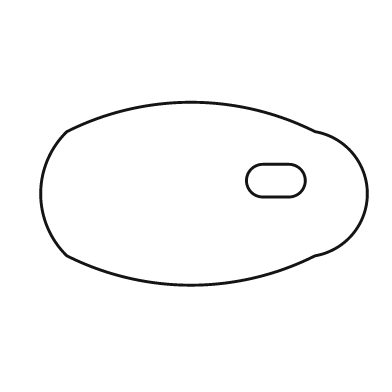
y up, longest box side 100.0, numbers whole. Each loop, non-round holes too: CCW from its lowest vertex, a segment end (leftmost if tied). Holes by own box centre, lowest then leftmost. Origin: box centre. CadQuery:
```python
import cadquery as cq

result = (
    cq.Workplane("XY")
    .moveTo(-42.0, -19.0)
    .threePointArc((-4.0, -28.0), (34.0, -19.0))
    .threePointArc((50.0, 0.0), (34.0, 19.0))
    .threePointArc((-4.0, 28.0), (-42.0, 19.0))
    .threePointArc((-50.0, 0.0), (-42.0, -19.0))
    .close()
    .moveTo(18.0, -1.0)
    .lineTo(26.0, -1.0)
    .threePointArc((31.0, 4.0), (26.0, 9.0))
    .lineTo(18.0, 9.0)
    .threePointArc((13.0, 4.0), (18.0, -1.0))
    .close()
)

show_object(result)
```